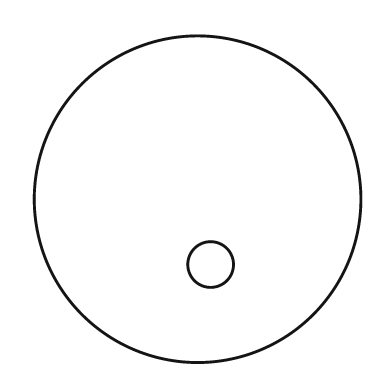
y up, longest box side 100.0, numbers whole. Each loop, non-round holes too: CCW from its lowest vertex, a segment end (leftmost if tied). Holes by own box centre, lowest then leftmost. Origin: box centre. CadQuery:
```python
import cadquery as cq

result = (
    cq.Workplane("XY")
    .moveTo(0.0, 0.0)
    .circle(50.0)
    .moveTo(4.0, -20.0)
    .circle(7.0)
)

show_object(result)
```